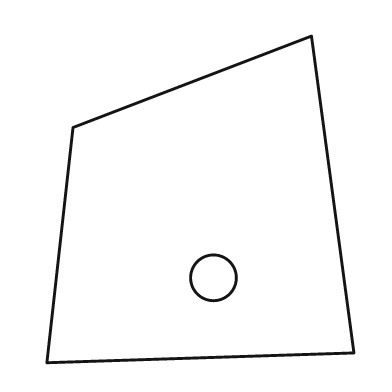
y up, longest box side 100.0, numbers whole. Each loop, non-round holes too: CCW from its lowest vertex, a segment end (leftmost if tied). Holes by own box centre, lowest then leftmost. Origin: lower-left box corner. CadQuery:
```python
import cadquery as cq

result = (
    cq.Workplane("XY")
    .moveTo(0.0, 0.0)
    .lineTo(94.0, 3.0)
    .lineTo(81.0, 100.0)
    .lineTo(8.0, 72.0)
    .close()
    .moveTo(51.0, 26.0)
    .circle(7.0)
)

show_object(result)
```